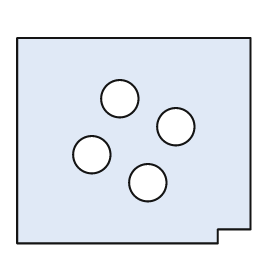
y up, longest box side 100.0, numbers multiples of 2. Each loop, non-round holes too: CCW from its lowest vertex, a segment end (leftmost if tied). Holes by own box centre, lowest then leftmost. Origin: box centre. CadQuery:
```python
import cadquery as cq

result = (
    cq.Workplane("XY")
    .moveTo(-50.0, -44.0)
    .lineTo(36.0, -44.0)
    .lineTo(36.0, -38.0)
    .lineTo(50.0, -38.0)
    .lineTo(50.0, 44.0)
    .lineTo(-50.0, 44.0)
    .close()
    .moveTo(6.0, -18.0)
    .circle(8.0)
    .moveTo(-18.0, -6.0)
    .circle(8.0)
    .moveTo(18.0, 6.0)
    .circle(8.0)
    .moveTo(-6.0, 18.0)
    .circle(8.0)
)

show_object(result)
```